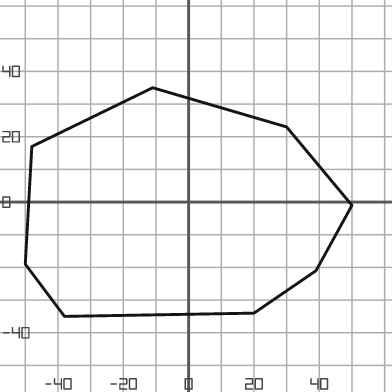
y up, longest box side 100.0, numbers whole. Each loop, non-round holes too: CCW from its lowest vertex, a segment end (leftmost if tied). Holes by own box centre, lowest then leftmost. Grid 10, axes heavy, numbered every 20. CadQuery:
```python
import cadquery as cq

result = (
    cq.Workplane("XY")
    .moveTo(-38.0, -35.0)
    .lineTo(20.0, -34.0)
    .lineTo(39.0, -21.0)
    .lineTo(50.0, -1.0)
    .lineTo(30.0, 23.0)
    .lineTo(-11.0, 35.0)
    .lineTo(-48.0, 17.0)
    .lineTo(-50.0, -19.0)
    .close()
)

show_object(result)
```